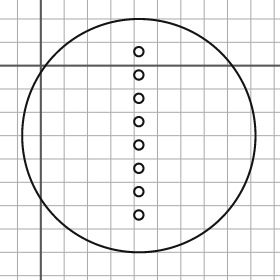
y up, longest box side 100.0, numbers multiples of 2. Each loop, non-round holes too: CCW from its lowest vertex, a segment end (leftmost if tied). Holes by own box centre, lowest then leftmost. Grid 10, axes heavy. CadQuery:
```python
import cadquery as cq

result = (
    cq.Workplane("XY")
    .moveTo(42.0, -30.0)
    .circle(50.0)
    .moveTo(42.0, -64.0)
    .circle(2.0)
    .moveTo(42.0, -54.0)
    .circle(2.0)
    .moveTo(42.0, -44.0)
    .circle(2.0)
    .moveTo(42.0, -34.0)
    .circle(2.0)
    .moveTo(42.0, -24.0)
    .circle(2.0)
    .moveTo(42.0, -14.0)
    .circle(2.0)
    .moveTo(42.0, -4.0)
    .circle(2.0)
    .moveTo(42.0, 6.0)
    .circle(2.0)
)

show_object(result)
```